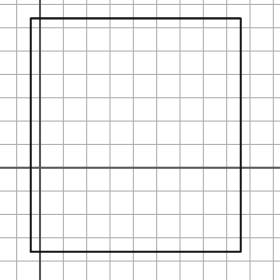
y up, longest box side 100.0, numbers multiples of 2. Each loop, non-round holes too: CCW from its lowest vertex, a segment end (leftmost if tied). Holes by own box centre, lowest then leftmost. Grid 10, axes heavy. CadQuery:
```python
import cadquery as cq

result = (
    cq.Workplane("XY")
    .moveTo(-4.0, -36.0)
    .lineTo(86.0, -36.0)
    .lineTo(86.0, 64.0)
    .lineTo(-4.0, 64.0)
    .close()
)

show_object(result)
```